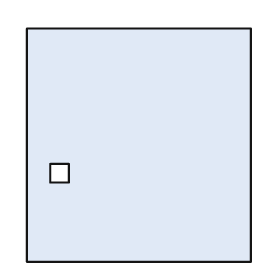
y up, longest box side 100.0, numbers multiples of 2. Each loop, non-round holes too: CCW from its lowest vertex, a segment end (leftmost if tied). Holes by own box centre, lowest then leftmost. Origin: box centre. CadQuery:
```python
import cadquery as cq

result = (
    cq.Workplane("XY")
    .moveTo(-48.0, -50.0)
    .lineTo(48.0, -50.0)
    .lineTo(48.0, 50.0)
    .lineTo(-48.0, 50.0)
    .close()
    .moveTo(-38.0, -16.0)
    .lineTo(-30.0, -16.0)
    .lineTo(-30.0, -8.0)
    .lineTo(-38.0, -8.0)
    .close()
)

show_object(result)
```